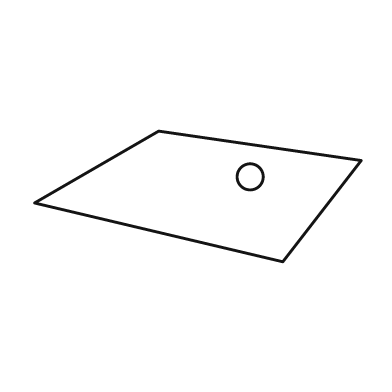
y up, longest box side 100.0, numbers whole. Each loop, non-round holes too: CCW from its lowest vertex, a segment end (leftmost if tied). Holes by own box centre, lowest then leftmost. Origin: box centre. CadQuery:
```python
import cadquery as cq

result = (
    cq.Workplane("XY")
    .moveTo(26.0, -20.0)
    .lineTo(50.0, 11.0)
    .lineTo(-12.0, 20.0)
    .lineTo(-50.0, -2.0)
    .close()
    .moveTo(16.0, 6.0)
    .circle(4.0)
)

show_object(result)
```